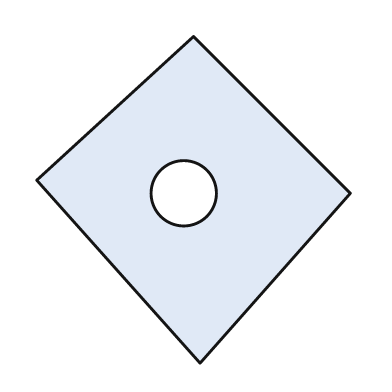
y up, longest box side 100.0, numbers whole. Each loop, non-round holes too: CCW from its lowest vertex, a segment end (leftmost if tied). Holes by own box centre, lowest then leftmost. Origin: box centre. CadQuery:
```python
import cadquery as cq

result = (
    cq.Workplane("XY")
    .moveTo(2.0, -50.0)
    .lineTo(48.0, 2.0)
    .lineTo(0.0, 50.0)
    .lineTo(-48.0, 6.0)
    .close()
    .moveTo(-3.0, 2.0)
    .circle(10.0)
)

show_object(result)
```